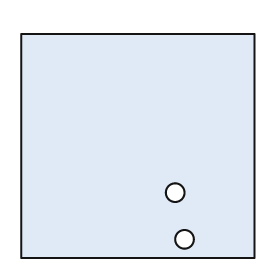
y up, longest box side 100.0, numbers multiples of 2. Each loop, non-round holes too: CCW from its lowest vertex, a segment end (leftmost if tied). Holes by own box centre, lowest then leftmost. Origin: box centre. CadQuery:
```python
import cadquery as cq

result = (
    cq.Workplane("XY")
    .moveTo(-50.0, -48.0)
    .lineTo(50.0, -48.0)
    .lineTo(50.0, 48.0)
    .lineTo(-50.0, 48.0)
    .close()
    .moveTo(20.0, -40.0)
    .circle(4.0)
    .moveTo(16.0, -20.0)
    .circle(4.0)
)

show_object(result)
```